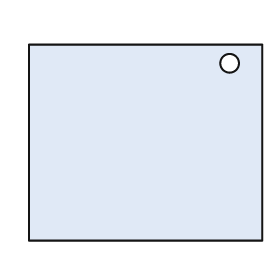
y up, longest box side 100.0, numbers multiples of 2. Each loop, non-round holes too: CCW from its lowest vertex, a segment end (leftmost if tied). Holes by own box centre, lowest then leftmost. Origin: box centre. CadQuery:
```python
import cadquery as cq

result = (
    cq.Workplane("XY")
    .moveTo(-50.0, -42.0)
    .lineTo(50.0, -42.0)
    .lineTo(50.0, 42.0)
    .lineTo(-50.0, 42.0)
    .close()
    .moveTo(36.0, 34.0)
    .circle(4.0)
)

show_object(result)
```